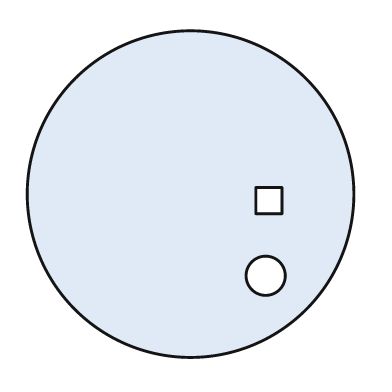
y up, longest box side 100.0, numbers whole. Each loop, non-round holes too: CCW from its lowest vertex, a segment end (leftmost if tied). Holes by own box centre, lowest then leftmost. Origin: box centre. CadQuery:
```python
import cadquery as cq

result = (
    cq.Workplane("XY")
    .moveTo(0.0, 0.0)
    .circle(50.0)
    .moveTo(23.0, -25.0)
    .circle(6.0)
    .moveTo(20.0, -6.0)
    .lineTo(28.0, -6.0)
    .lineTo(28.0, 2.0)
    .lineTo(20.0, 2.0)
    .close()
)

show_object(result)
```